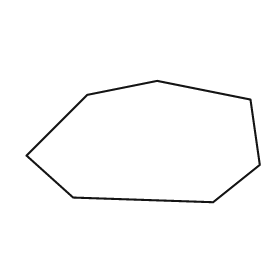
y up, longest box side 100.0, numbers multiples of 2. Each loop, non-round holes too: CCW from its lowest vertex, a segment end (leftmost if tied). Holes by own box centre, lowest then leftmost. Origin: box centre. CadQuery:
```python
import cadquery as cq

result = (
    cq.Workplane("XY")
    .moveTo(30.0, -26.0)
    .lineTo(50.0, -10.0)
    .lineTo(46.0, 18.0)
    .lineTo(6.0, 26.0)
    .lineTo(-24.0, 20.0)
    .lineTo(-50.0, -6.0)
    .lineTo(-30.0, -24.0)
    .close()
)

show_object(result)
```